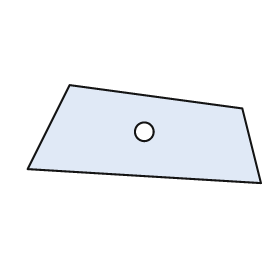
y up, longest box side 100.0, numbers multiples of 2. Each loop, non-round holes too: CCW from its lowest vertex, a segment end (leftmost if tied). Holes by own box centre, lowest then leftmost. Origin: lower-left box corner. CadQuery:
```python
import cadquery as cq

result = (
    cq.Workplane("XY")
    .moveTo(100.0, 0.0)
    .lineTo(92.0, 32.0)
    .lineTo(18.0, 42.0)
    .lineTo(0.0, 6.0)
    .close()
    .moveTo(50.0, 22.0)
    .circle(4.0)
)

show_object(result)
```